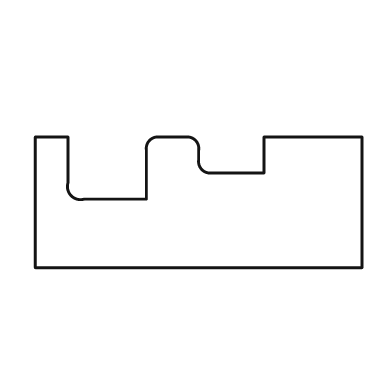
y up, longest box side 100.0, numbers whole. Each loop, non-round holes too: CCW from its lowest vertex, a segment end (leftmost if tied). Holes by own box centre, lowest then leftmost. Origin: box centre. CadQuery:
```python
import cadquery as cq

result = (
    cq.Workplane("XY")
    .moveTo(-50.0, -20.0)
    .lineTo(50.0, -20.0)
    .lineTo(50.0, 20.0)
    .lineTo(20.0, 20.0)
    .lineTo(20.0, 9.0)
    .lineTo(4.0, 9.0)
    .threePointArc((1.0, 10.0), (0.0, 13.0))
    .lineTo(0.0, 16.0)
    .threePointArc((-1.0, 19.0), (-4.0, 20.0))
    .lineTo(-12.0, 20.0)
    .threePointArc((-15.0, 19.0), (-16.0, 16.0))
    .lineTo(-16.0, 1.0)
    .lineTo(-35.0, 1.0)
    .threePointArc((-39.0, 2.0), (-40.0, 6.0))
    .lineTo(-40.0, 20.0)
    .lineTo(-50.0, 20.0)
    .close()
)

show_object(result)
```